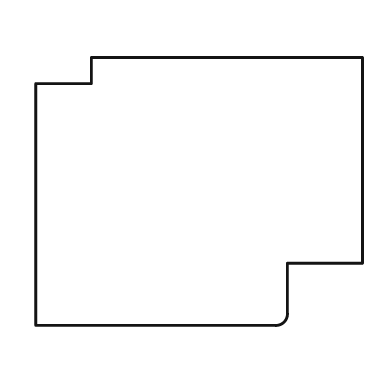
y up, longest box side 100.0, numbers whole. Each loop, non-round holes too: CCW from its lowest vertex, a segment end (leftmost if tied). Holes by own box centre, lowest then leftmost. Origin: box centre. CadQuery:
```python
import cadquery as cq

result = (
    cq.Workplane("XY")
    .moveTo(-50.0, -41.0)
    .lineTo(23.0, -41.0)
    .threePointArc((26.0, -40.0), (27.0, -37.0))
    .lineTo(27.0, -22.0)
    .lineTo(50.0, -22.0)
    .lineTo(50.0, 41.0)
    .lineTo(-33.0, 41.0)
    .lineTo(-33.0, 33.0)
    .lineTo(-50.0, 33.0)
    .close()
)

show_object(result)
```